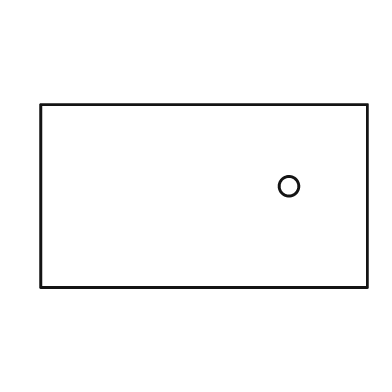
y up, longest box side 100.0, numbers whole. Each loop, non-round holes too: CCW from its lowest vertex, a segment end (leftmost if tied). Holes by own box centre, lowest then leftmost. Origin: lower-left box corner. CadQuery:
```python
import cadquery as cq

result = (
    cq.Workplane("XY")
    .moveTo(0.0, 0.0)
    .lineTo(100.0, 0.0)
    .lineTo(100.0, 56.0)
    .lineTo(0.0, 56.0)
    .close()
    .moveTo(76.0, 31.0)
    .circle(3.0)
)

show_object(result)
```